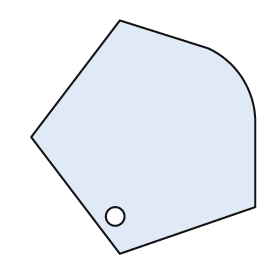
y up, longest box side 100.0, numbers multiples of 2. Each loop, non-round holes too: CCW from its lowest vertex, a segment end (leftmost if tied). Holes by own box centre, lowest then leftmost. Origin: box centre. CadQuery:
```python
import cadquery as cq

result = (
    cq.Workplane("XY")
    .moveTo(-10.0, -50.0)
    .lineTo(48.0, -30.0)
    .lineTo(48.0, 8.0)
    .threePointArc((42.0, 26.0), (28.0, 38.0))
    .lineTo(-10.0, 50.0)
    .lineTo(-48.0, 0.0)
    .close()
    .moveTo(-12.0, -34.0)
    .circle(4.0)
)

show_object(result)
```